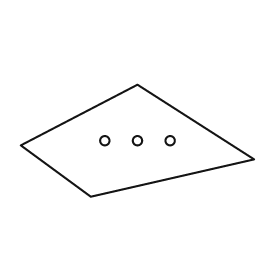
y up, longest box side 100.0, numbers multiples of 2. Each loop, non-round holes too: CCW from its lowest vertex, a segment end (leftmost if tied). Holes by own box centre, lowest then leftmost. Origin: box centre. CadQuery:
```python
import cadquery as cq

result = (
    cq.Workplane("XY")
    .moveTo(-20.0, -24.0)
    .lineTo(50.0, -8.0)
    .lineTo(0.0, 24.0)
    .lineTo(-50.0, -2.0)
    .close()
    .moveTo(-14.0, 0.0)
    .circle(2.0)
    .moveTo(0.0, 0.0)
    .circle(2.0)
    .moveTo(14.0, 0.0)
    .circle(2.0)
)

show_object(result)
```